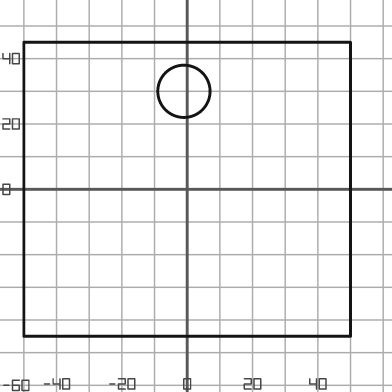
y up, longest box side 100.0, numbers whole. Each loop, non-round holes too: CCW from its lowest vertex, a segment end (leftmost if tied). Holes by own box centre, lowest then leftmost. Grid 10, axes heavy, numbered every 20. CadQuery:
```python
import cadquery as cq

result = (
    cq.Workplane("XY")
    .moveTo(-50.0, -45.0)
    .lineTo(50.0, -45.0)
    .lineTo(50.0, 45.0)
    .lineTo(-50.0, 45.0)
    .close()
    .moveTo(-1.0, 30.0)
    .circle(8.0)
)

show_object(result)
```